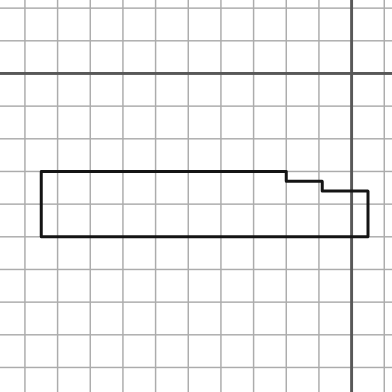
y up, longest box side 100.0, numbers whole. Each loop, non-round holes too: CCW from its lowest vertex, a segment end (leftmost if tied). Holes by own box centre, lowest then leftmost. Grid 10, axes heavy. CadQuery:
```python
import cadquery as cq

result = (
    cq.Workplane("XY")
    .moveTo(-95.0, -50.0)
    .lineTo(5.0, -50.0)
    .lineTo(5.0, -36.0)
    .lineTo(-9.0, -36.0)
    .lineTo(-9.0, -33.0)
    .lineTo(-20.0, -33.0)
    .lineTo(-20.0, -30.0)
    .lineTo(-95.0, -30.0)
    .close()
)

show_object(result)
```